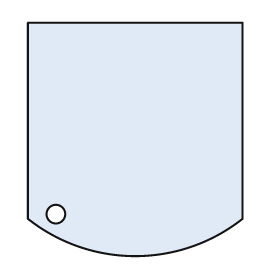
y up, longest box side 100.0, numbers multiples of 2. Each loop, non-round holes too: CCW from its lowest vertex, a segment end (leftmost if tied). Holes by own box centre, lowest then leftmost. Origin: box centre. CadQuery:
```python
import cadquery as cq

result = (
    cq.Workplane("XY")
    .moveTo(-46.0, -34.0)
    .threePointArc((0.0, -50.0), (46.0, -34.0))
    .lineTo(46.0, 50.0)
    .lineTo(-46.0, 50.0)
    .close()
    .moveTo(-34.0, -32.0)
    .circle(4.0)
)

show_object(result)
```